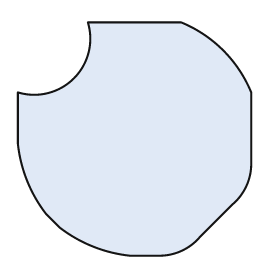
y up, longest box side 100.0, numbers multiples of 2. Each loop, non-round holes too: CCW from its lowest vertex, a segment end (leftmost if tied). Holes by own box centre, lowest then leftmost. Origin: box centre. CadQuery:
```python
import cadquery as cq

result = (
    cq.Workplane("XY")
    .moveTo(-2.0, -50.0)
    .lineTo(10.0, -50.0)
    .threePointArc((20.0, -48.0), (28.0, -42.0))
    .lineTo(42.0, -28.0)
    .threePointArc((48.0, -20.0), (50.0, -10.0))
    .lineTo(50.0, 20.0)
    .threePointArc((38.0, 38.0), (20.0, 50.0))
    .lineTo(-20.0, 50.0)
    .threePointArc((-26.0, 26.0), (-50.0, 20.0))
    .lineTo(-50.0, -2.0)
    .threePointArc((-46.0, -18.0), (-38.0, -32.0))
    .lineTo(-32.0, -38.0)
    .threePointArc((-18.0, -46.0), (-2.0, -50.0))
    .close()
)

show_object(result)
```